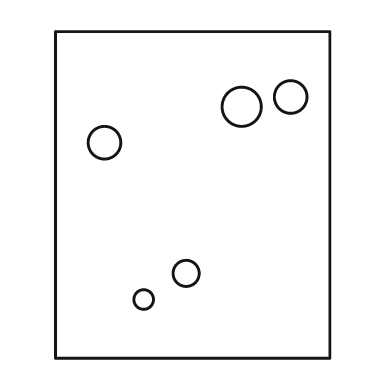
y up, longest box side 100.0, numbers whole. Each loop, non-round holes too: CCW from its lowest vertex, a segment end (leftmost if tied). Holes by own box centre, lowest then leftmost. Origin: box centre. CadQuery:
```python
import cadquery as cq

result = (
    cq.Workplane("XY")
    .moveTo(-42.0, -50.0)
    .lineTo(42.0, -50.0)
    .lineTo(42.0, 50.0)
    .lineTo(-42.0, 50.0)
    .close()
    .moveTo(-15.0, -32.0)
    .circle(3.0)
    .moveTo(-2.0, -24.0)
    .circle(4.0)
    .moveTo(-27.0, 16.0)
    .circle(5.0)
    .moveTo(15.0, 27.0)
    .circle(6.0)
    .moveTo(30.0, 30.0)
    .circle(5.0)
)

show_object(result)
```